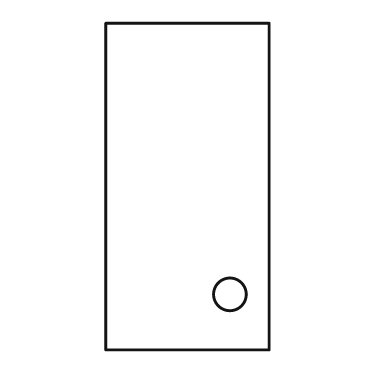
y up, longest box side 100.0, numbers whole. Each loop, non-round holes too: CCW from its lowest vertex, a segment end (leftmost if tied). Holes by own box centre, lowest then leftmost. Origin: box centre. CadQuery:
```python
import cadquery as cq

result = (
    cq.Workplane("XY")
    .moveTo(-25.0, -50.0)
    .lineTo(25.0, -50.0)
    .lineTo(25.0, 50.0)
    .lineTo(-25.0, 50.0)
    .close()
    .moveTo(13.0, -33.0)
    .circle(5.0)
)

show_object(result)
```